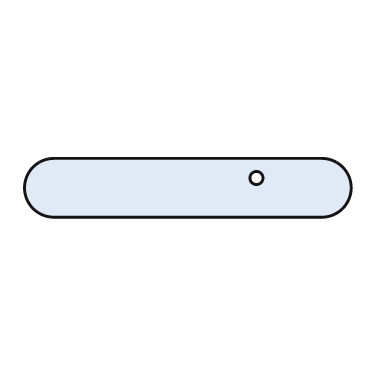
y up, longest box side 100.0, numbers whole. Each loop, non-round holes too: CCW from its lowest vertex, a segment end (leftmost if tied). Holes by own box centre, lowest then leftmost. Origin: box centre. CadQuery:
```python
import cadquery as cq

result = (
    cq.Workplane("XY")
    .moveTo(-41.0, -9.0)
    .lineTo(41.0, -9.0)
    .threePointArc((50.0, 0.0), (41.0, 9.0))
    .lineTo(-41.0, 9.0)
    .threePointArc((-50.0, 0.0), (-41.0, -9.0))
    .close()
    .moveTo(21.0, 3.0)
    .circle(2.0)
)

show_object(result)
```